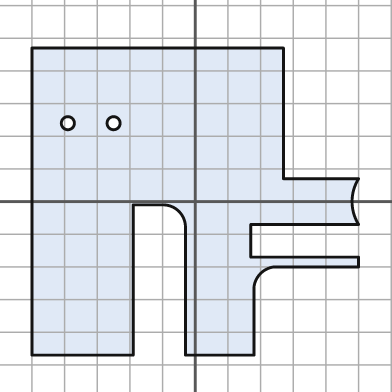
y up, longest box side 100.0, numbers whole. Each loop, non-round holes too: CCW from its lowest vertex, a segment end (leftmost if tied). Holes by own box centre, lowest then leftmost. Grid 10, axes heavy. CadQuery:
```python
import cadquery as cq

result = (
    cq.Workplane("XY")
    .moveTo(-50.0, -47.0)
    .lineTo(-19.0, -47.0)
    .lineTo(-19.0, -1.0)
    .lineTo(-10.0, -1.0)
    .threePointArc((-5.0, -3.0), (-3.0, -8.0))
    .lineTo(-3.0, -47.0)
    .lineTo(18.0, -47.0)
    .lineTo(18.0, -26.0)
    .threePointArc((20.0, -22.0), (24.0, -20.0))
    .lineTo(50.0, -20.0)
    .lineTo(50.0, -17.0)
    .lineTo(17.0, -17.0)
    .lineTo(17.0, -7.0)
    .lineTo(50.0, -7.0)
    .threePointArc((48.0, 0.0), (50.0, 7.0))
    .lineTo(27.0, 7.0)
    .lineTo(27.0, 47.0)
    .lineTo(-50.0, 47.0)
    .close()
    .moveTo(-39.0, 24.0)
    .circle(2.0)
    .moveTo(-25.0, 24.0)
    .circle(2.0)
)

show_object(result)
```